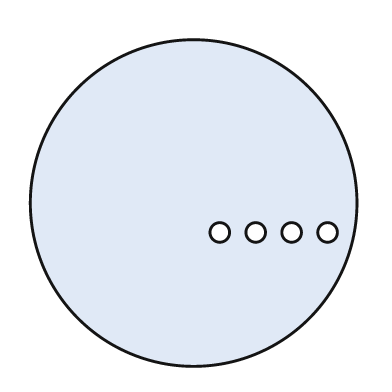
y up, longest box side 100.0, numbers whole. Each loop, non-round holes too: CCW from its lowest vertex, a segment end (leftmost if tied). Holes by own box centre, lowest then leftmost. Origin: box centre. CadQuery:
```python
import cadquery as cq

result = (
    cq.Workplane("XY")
    .moveTo(0.0, 0.0)
    .circle(50.0)
    .moveTo(8.0, -9.0)
    .circle(3.0)
    .moveTo(19.0, -9.0)
    .circle(3.0)
    .moveTo(30.0, -9.0)
    .circle(3.0)
    .moveTo(41.0, -9.0)
    .circle(3.0)
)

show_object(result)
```